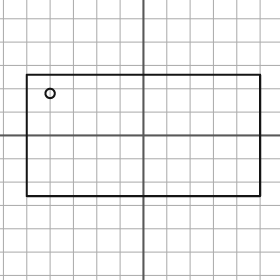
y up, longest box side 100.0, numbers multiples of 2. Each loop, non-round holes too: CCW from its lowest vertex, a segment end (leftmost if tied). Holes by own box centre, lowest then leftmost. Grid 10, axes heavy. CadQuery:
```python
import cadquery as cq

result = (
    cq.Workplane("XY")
    .moveTo(-50.0, -26.0)
    .lineTo(50.0, -26.0)
    .lineTo(50.0, 26.0)
    .lineTo(-50.0, 26.0)
    .close()
    .moveTo(-40.0, 18.0)
    .circle(2.0)
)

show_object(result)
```